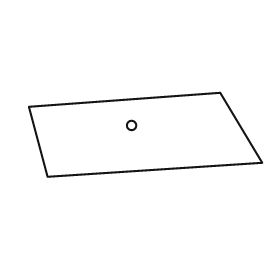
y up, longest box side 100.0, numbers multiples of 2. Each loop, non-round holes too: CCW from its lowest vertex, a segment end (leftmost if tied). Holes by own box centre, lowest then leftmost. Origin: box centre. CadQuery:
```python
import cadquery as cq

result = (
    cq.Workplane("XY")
    .moveTo(-42.0, -18.0)
    .lineTo(50.0, -12.0)
    .lineTo(32.0, 18.0)
    .lineTo(-50.0, 12.0)
    .close()
    .moveTo(-6.0, 4.0)
    .circle(2.0)
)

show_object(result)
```